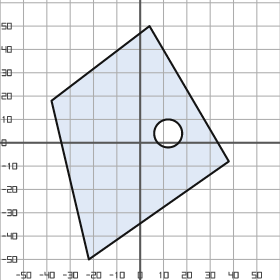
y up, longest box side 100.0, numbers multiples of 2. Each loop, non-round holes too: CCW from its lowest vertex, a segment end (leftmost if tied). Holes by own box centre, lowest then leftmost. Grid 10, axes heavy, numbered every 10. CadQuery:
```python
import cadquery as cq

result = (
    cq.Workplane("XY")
    .moveTo(-22.0, -50.0)
    .lineTo(38.0, -8.0)
    .lineTo(4.0, 50.0)
    .lineTo(-38.0, 18.0)
    .close()
    .moveTo(12.0, 4.0)
    .circle(6.0)
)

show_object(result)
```